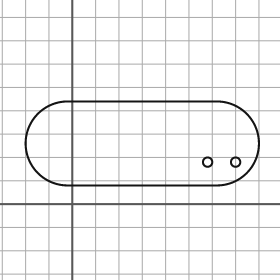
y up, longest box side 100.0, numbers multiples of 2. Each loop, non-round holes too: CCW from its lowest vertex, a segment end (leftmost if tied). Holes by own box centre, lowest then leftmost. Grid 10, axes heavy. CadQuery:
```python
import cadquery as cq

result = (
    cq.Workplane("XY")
    .moveTo(-2.0, 8.0)
    .lineTo(62.0, 8.0)
    .threePointArc((80.0, 26.0), (62.0, 44.0))
    .lineTo(-2.0, 44.0)
    .threePointArc((-20.0, 26.0), (-2.0, 8.0))
    .close()
    .moveTo(58.0, 18.0)
    .circle(2.0)
    .moveTo(70.0, 18.0)
    .circle(2.0)
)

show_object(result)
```